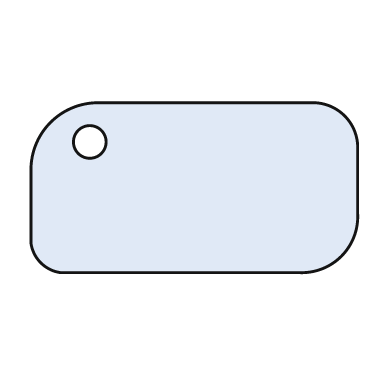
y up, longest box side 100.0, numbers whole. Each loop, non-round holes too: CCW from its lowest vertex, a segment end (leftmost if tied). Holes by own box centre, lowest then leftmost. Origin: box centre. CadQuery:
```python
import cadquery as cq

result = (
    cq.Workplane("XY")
    .moveTo(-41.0, -26.0)
    .lineTo(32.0, -26.0)
    .threePointArc((45.0, -21.0), (50.0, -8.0))
    .lineTo(50.0, 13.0)
    .threePointArc((46.0, 22.0), (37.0, 26.0))
    .lineTo(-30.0, 26.0)
    .threePointArc((-44.0, 20.0), (-50.0, 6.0))
    .lineTo(-50.0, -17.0)
    .threePointArc((-47.0, -23.0), (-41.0, -26.0))
    .close()
    .moveTo(-32.0, 14.0)
    .circle(5.0)
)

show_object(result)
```